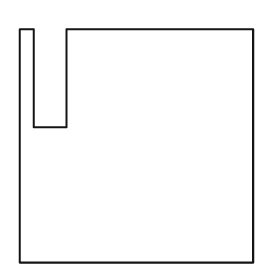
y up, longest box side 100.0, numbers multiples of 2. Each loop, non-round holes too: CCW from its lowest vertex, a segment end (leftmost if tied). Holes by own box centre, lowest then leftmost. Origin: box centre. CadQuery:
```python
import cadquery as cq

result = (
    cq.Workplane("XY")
    .moveTo(-50.0, -50.0)
    .lineTo(50.0, -50.0)
    .lineTo(50.0, 50.0)
    .lineTo(-30.0, 50.0)
    .lineTo(-30.0, 8.0)
    .lineTo(-44.0, 8.0)
    .lineTo(-44.0, 50.0)
    .lineTo(-50.0, 50.0)
    .close()
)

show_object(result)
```